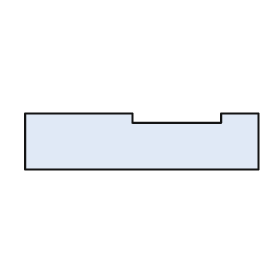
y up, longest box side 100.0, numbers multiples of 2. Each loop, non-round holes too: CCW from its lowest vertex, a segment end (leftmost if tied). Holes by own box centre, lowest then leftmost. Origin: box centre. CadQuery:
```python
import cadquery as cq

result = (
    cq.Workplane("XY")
    .moveTo(-50.0, -12.0)
    .lineTo(50.0, -12.0)
    .lineTo(50.0, 12.0)
    .lineTo(34.0, 12.0)
    .lineTo(34.0, 8.0)
    .lineTo(-4.0, 8.0)
    .lineTo(-4.0, 12.0)
    .lineTo(-50.0, 12.0)
    .close()
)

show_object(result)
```